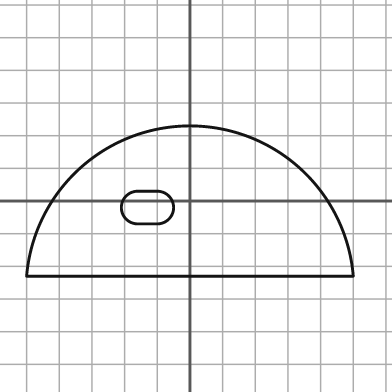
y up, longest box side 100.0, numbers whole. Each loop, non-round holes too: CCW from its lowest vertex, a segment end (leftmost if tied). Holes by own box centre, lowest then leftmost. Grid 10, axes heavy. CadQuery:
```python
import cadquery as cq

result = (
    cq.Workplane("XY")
    .moveTo(-50.0, -23.0)
    .lineTo(50.0, -23.0)
    .threePointArc((0.0, 23.0), (-50.0, -23.0))
    .close()
    .moveTo(-16.0, -7.0)
    .lineTo(-10.0, -7.0)
    .threePointArc((-5.0, -2.0), (-10.0, 3.0))
    .lineTo(-16.0, 3.0)
    .threePointArc((-21.0, -2.0), (-16.0, -7.0))
    .close()
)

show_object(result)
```